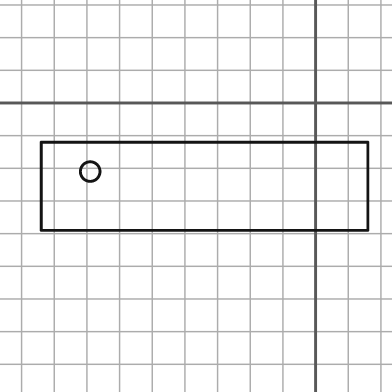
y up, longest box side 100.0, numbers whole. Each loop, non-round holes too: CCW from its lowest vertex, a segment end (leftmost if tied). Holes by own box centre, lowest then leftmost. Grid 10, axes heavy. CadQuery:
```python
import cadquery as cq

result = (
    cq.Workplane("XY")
    .moveTo(-84.0, -39.0)
    .lineTo(16.0, -39.0)
    .lineTo(16.0, -12.0)
    .lineTo(-84.0, -12.0)
    .close()
    .moveTo(-69.0, -21.0)
    .circle(3.0)
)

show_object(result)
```